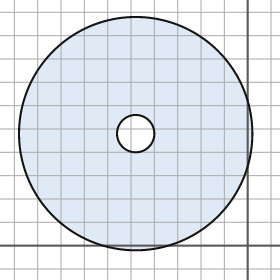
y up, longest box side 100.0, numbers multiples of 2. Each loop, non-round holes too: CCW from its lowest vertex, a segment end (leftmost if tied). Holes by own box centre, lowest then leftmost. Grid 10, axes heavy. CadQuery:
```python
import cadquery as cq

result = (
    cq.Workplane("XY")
    .moveTo(-48.0, 48.0)
    .circle(50.0)
    .moveTo(-48.0, 48.0)
    .circle(8.0)
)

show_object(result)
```